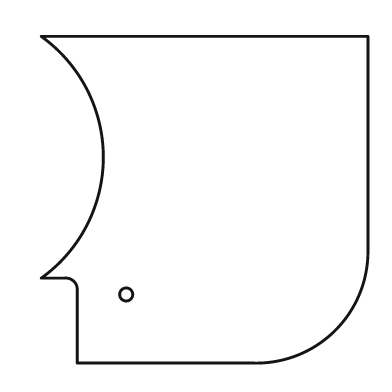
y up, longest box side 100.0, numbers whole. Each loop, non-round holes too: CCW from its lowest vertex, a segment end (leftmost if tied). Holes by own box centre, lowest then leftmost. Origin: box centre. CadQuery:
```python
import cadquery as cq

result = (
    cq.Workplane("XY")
    .moveTo(-39.0, -50.0)
    .lineTo(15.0, -50.0)
    .threePointArc((40.0, -40.0), (50.0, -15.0))
    .lineTo(50.0, 50.0)
    .lineTo(-50.0, 50.0)
    .threePointArc((-31.0, 13.0), (-50.0, -24.0))
    .lineTo(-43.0, -24.0)
    .threePointArc((-40.0, -25.0), (-39.0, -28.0))
    .close()
    .moveTo(-24.0, -29.0)
    .circle(2.0)
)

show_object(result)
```